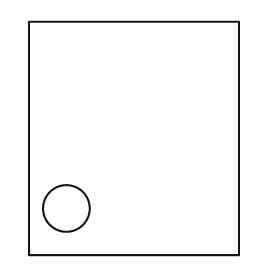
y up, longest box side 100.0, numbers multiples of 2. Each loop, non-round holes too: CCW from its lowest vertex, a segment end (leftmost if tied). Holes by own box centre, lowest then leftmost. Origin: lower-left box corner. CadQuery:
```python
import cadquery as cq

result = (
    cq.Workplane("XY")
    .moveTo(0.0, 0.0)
    .lineTo(90.0, 0.0)
    .lineTo(90.0, 100.0)
    .lineTo(0.0, 100.0)
    .close()
    .moveTo(16.0, 20.0)
    .circle(10.0)
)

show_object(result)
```